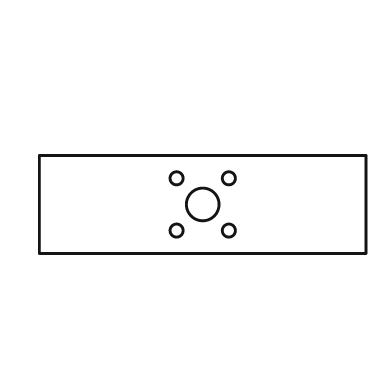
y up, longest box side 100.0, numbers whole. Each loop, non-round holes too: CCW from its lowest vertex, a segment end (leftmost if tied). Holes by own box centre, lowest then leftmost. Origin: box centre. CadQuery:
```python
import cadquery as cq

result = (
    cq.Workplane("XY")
    .moveTo(-50.0, -15.0)
    .lineTo(50.0, -15.0)
    .lineTo(50.0, 15.0)
    .lineTo(-50.0, 15.0)
    .close()
    .moveTo(-8.0, -8.0)
    .circle(2.0)
    .moveTo(8.0, -8.0)
    .circle(2.0)
    .moveTo(0.0, 0.0)
    .circle(5.0)
    .moveTo(-8.0, 8.0)
    .circle(2.0)
    .moveTo(8.0, 8.0)
    .circle(2.0)
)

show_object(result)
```